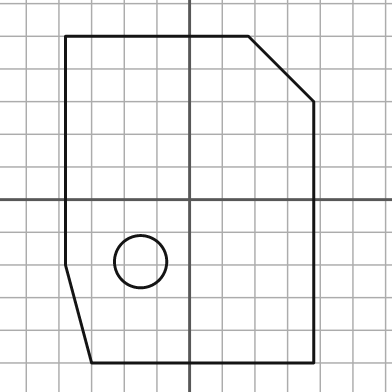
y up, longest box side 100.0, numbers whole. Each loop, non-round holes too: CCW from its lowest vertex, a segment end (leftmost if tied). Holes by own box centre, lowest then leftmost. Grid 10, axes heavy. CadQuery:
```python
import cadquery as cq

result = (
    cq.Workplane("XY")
    .moveTo(-30.0, -50.0)
    .lineTo(38.0, -50.0)
    .lineTo(38.0, 30.0)
    .lineTo(18.0, 50.0)
    .lineTo(-38.0, 50.0)
    .lineTo(-38.0, -20.0)
    .close()
    .moveTo(-15.0, -19.0)
    .circle(8.0)
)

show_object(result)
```